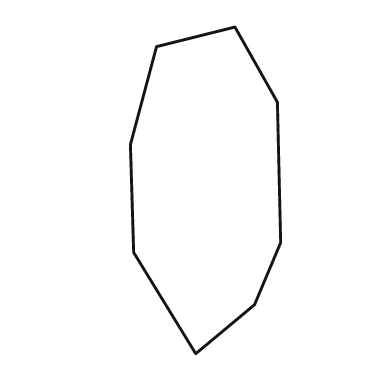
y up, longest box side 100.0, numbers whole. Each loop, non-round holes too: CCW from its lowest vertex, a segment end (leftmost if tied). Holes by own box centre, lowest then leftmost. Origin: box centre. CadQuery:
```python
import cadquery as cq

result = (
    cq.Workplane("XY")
    .moveTo(-3.0, -50.0)
    .lineTo(15.0, -35.0)
    .lineTo(23.0, -16.0)
    .lineTo(22.0, 27.0)
    .lineTo(9.0, 50.0)
    .lineTo(-15.0, 44.0)
    .lineTo(-23.0, 14.0)
    .lineTo(-22.0, -19.0)
    .close()
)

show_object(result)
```